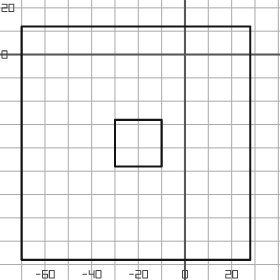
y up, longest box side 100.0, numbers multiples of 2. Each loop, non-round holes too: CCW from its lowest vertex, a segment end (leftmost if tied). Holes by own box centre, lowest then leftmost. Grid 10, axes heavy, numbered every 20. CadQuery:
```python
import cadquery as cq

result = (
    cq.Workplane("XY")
    .moveTo(-70.0, -88.0)
    .lineTo(28.0, -88.0)
    .lineTo(28.0, 12.0)
    .lineTo(-70.0, 12.0)
    .close()
    .moveTo(-30.0, -48.0)
    .lineTo(-10.0, -48.0)
    .lineTo(-10.0, -28.0)
    .lineTo(-30.0, -28.0)
    .close()
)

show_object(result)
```